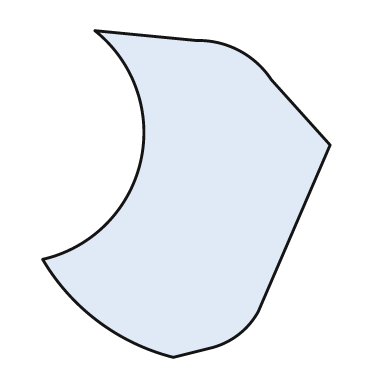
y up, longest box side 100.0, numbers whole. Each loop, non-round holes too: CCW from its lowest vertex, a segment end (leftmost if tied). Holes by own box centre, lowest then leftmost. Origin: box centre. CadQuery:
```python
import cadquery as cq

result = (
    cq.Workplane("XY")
    .moveTo(-4.0, -50.0)
    .lineTo(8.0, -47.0)
    .threePointArc((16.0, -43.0), (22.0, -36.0))
    .lineTo(44.0, 15.0)
    .lineTo(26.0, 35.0)
    .threePointArc((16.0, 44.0), (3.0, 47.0))
    .lineTo(-28.0, 50.0)
    .threePointArc((-14.0, 10.0), (-44.0, -20.0))
    .threePointArc((-27.0, -39.0), (-4.0, -50.0))
    .close()
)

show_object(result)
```